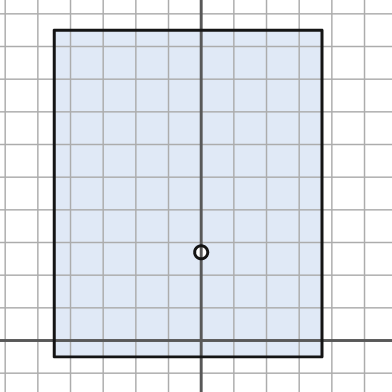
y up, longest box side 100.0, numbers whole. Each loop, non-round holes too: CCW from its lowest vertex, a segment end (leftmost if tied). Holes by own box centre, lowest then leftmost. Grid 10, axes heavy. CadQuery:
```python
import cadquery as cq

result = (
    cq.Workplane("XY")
    .moveTo(-45.0, -5.0)
    .lineTo(37.0, -5.0)
    .lineTo(37.0, 95.0)
    .lineTo(-45.0, 95.0)
    .close()
    .moveTo(0.0, 27.0)
    .circle(2.0)
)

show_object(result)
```